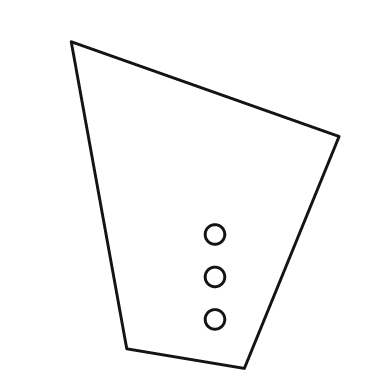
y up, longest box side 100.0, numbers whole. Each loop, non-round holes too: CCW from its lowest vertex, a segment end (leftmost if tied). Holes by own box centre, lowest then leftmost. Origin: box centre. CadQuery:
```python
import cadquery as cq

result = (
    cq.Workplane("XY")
    .moveTo(12.0, -50.0)
    .lineTo(41.0, 21.0)
    .lineTo(-41.0, 50.0)
    .lineTo(-24.0, -44.0)
    .close()
    .moveTo(3.0, -35.0)
    .circle(3.0)
    .moveTo(3.0, -22.0)
    .circle(3.0)
    .moveTo(3.0, -9.0)
    .circle(3.0)
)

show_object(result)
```